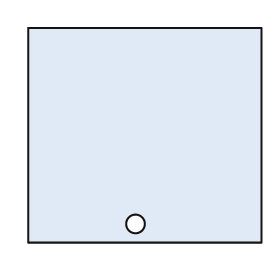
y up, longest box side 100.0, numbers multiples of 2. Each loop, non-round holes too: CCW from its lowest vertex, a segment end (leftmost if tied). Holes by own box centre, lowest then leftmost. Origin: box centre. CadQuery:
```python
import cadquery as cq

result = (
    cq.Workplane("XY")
    .moveTo(-50.0, -46.0)
    .lineTo(50.0, -46.0)
    .lineTo(50.0, 46.0)
    .lineTo(-50.0, 46.0)
    .close()
    .moveTo(-4.0, -38.0)
    .circle(4.0)
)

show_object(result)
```